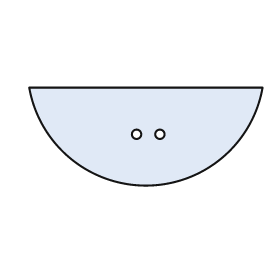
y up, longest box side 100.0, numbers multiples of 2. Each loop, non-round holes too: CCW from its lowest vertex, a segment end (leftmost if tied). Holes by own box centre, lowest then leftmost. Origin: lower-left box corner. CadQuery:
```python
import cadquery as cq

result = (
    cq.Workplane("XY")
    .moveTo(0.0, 42.0)
    .threePointArc((50.0, 0.0), (100.0, 42.0))
    .close()
    .moveTo(46.0, 22.0)
    .circle(2.0)
    .moveTo(56.0, 22.0)
    .circle(2.0)
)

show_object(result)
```